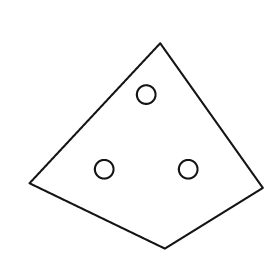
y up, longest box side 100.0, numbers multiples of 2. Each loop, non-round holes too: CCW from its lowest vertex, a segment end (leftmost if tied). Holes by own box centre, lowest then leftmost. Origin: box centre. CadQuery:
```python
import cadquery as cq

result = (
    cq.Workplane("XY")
    .moveTo(8.0, -44.0)
    .lineTo(50.0, -18.0)
    .lineTo(6.0, 44.0)
    .lineTo(-50.0, -16.0)
    .close()
    .moveTo(-18.0, -10.0)
    .circle(4.0)
    .moveTo(18.0, -10.0)
    .circle(4.0)
    .moveTo(0.0, 22.0)
    .circle(4.0)
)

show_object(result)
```